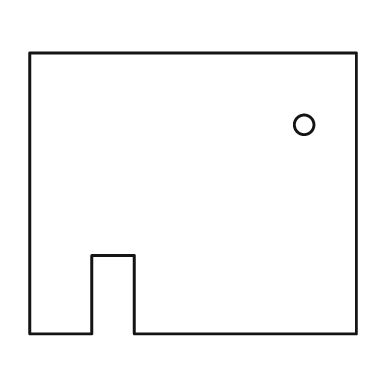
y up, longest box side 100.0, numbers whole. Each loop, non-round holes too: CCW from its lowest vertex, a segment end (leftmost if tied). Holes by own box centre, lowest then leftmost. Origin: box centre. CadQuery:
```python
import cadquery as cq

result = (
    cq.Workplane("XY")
    .moveTo(-50.0, -43.0)
    .lineTo(-31.0, -43.0)
    .lineTo(-31.0, -19.0)
    .lineTo(-18.0, -19.0)
    .lineTo(-18.0, -43.0)
    .lineTo(50.0, -43.0)
    .lineTo(50.0, 43.0)
    .lineTo(-50.0, 43.0)
    .close()
    .moveTo(34.0, 21.0)
    .circle(3.0)
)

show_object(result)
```